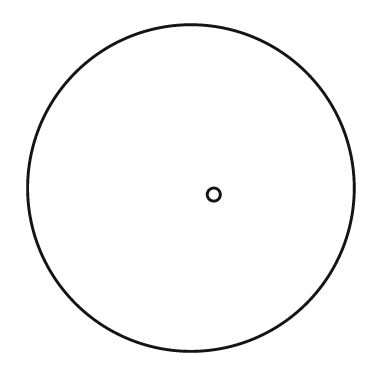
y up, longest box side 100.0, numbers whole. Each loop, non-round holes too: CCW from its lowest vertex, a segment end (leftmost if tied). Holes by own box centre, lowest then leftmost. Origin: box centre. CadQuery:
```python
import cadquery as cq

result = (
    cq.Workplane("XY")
    .moveTo(0.0, 0.0)
    .circle(50.0)
    .moveTo(7.0, -2.0)
    .circle(2.0)
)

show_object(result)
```